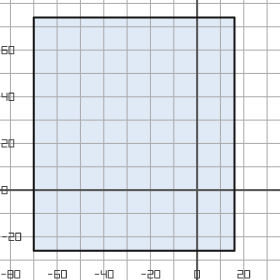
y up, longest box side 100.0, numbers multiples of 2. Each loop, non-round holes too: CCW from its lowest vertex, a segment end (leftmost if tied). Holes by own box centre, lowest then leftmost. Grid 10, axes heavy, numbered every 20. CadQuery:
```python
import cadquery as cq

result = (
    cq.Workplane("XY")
    .moveTo(-70.0, -26.0)
    .lineTo(16.0, -26.0)
    .lineTo(16.0, 74.0)
    .lineTo(-70.0, 74.0)
    .close()
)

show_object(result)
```